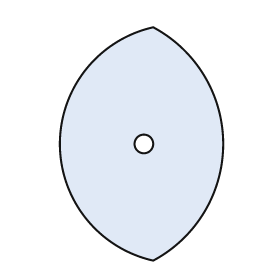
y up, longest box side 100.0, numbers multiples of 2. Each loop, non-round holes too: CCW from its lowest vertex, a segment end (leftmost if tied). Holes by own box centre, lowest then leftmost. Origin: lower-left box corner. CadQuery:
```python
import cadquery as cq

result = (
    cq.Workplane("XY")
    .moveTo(40.0, 0.0)
    .threePointArc((70.0, 50.0), (40.0, 100.0))
    .threePointArc((0.0, 50.0), (40.0, 0.0))
    .close()
    .moveTo(36.0, 50.0)
    .circle(4.0)
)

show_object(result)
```